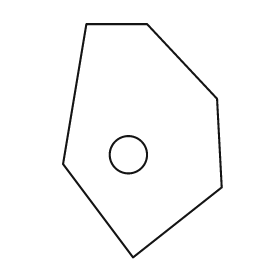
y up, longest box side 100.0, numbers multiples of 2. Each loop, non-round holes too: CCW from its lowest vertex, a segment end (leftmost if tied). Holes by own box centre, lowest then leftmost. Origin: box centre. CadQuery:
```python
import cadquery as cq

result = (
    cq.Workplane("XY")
    .moveTo(-4.0, -50.0)
    .lineTo(34.0, -20.0)
    .lineTo(32.0, 18.0)
    .lineTo(2.0, 50.0)
    .lineTo(-24.0, 50.0)
    .lineTo(-34.0, -10.0)
    .close()
    .moveTo(-6.0, -6.0)
    .circle(8.0)
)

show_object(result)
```